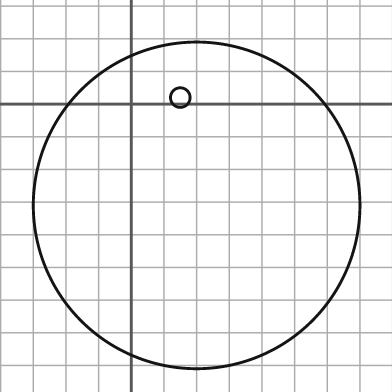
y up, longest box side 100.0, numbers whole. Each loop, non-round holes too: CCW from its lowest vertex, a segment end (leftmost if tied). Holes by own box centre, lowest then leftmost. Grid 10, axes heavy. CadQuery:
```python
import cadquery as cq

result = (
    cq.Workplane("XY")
    .moveTo(20.0, -31.0)
    .circle(50.0)
    .moveTo(15.0, 2.0)
    .circle(3.0)
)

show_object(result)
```